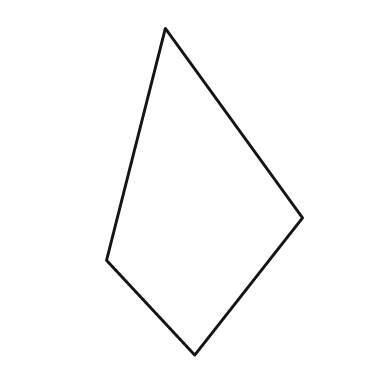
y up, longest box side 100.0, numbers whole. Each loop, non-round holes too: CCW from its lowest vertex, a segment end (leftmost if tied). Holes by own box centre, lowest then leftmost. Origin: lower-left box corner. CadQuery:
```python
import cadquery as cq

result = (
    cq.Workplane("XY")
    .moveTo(27.0, 0.0)
    .lineTo(60.0, 42.0)
    .lineTo(18.0, 100.0)
    .lineTo(0.0, 29.0)
    .close()
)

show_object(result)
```